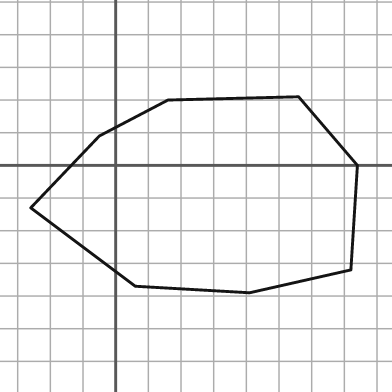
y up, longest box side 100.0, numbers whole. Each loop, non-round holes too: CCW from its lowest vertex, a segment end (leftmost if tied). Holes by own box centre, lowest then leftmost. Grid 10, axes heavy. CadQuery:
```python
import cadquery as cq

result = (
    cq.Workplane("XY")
    .moveTo(41.0, -39.0)
    .lineTo(72.0, -32.0)
    .lineTo(74.0, 0.0)
    .lineTo(56.0, 21.0)
    .lineTo(16.0, 20.0)
    .lineTo(-5.0, 9.0)
    .lineTo(-26.0, -13.0)
    .lineTo(6.0, -37.0)
    .close()
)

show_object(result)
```